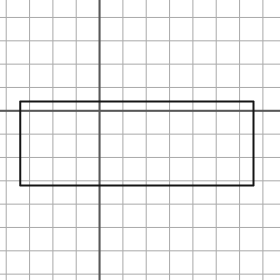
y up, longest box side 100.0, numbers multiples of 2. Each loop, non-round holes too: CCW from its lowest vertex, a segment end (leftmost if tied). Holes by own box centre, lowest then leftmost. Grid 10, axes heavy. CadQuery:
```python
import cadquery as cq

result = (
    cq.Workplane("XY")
    .moveTo(-34.0, -32.0)
    .lineTo(66.0, -32.0)
    .lineTo(66.0, 4.0)
    .lineTo(-34.0, 4.0)
    .close()
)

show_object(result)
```